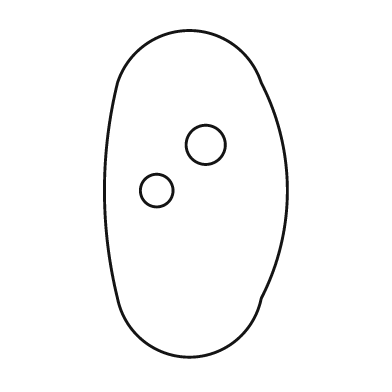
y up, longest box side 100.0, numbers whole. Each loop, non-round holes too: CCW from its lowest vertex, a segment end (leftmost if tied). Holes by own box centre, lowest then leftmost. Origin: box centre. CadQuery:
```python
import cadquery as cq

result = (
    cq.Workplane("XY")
    .moveTo(-24.0, -32.0)
    .threePointArc((-2.0, -50.0), (20.0, -32.0))
    .threePointArc((28.0, 1.0), (20.0, 34.0))
    .threePointArc((-2.0, 50.0), (-24.0, 34.0))
    .threePointArc((-28.0, 1.0), (-24.0, -32.0))
    .close()
    .moveTo(-12.0, 1.0)
    .circle(5.0)
    .moveTo(3.0, 15.0)
    .circle(6.0)
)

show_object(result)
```